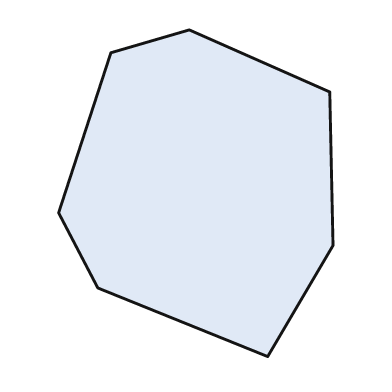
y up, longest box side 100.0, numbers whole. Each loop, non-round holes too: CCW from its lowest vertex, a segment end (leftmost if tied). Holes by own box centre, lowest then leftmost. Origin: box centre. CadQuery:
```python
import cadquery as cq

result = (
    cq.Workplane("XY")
    .moveTo(22.0, -50.0)
    .lineTo(42.0, -16.0)
    .lineTo(41.0, 31.0)
    .lineTo(-2.0, 50.0)
    .lineTo(-26.0, 43.0)
    .lineTo(-42.0, -6.0)
    .lineTo(-30.0, -29.0)
    .close()
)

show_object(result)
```